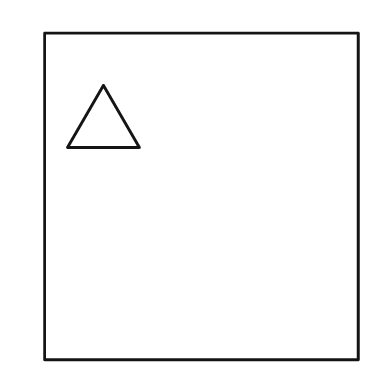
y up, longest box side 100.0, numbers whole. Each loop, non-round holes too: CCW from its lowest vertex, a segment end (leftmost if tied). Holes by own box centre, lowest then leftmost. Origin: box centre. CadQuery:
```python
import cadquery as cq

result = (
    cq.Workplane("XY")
    .moveTo(-48.0, -50.0)
    .lineTo(48.0, -50.0)
    .lineTo(48.0, 50.0)
    .lineTo(-48.0, 50.0)
    .close()
    .moveTo(-41.0, 15.0)
    .lineTo(-19.0, 15.0)
    .lineTo(-30.0, 34.0)
    .close()
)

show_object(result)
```